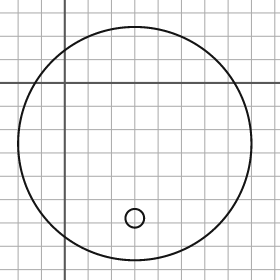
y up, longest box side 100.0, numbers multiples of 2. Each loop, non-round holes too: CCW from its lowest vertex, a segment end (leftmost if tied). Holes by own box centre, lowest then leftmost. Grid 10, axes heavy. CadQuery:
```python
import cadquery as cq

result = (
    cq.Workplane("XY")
    .moveTo(30.0, -26.0)
    .circle(50.0)
    .moveTo(30.0, -58.0)
    .circle(4.0)
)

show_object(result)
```